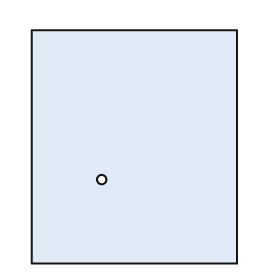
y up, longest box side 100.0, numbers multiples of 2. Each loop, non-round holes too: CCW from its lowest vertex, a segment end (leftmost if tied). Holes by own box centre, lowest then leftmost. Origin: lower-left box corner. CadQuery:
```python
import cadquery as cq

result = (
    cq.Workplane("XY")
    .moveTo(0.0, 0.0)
    .lineTo(88.0, 0.0)
    .lineTo(88.0, 100.0)
    .lineTo(0.0, 100.0)
    .close()
    .moveTo(30.0, 36.0)
    .circle(2.0)
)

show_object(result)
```